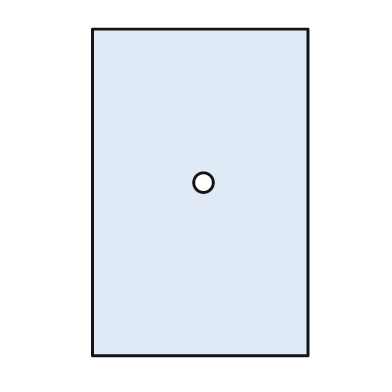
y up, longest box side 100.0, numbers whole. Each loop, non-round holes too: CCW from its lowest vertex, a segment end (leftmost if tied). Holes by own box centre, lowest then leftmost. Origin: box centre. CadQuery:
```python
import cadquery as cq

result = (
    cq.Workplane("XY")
    .moveTo(-33.0, -50.0)
    .lineTo(33.0, -50.0)
    .lineTo(33.0, 50.0)
    .lineTo(-33.0, 50.0)
    .close()
    .moveTo(1.0, 3.0)
    .circle(3.0)
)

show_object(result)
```